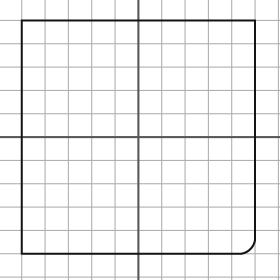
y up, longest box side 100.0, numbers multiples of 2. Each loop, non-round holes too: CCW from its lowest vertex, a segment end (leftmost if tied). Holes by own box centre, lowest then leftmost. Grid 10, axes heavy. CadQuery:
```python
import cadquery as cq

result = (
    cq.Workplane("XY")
    .moveTo(-50.0, -50.0)
    .lineTo(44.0, -50.0)
    .threePointArc((48.0, -48.0), (50.0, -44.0))
    .lineTo(50.0, 50.0)
    .lineTo(-50.0, 50.0)
    .close()
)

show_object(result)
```